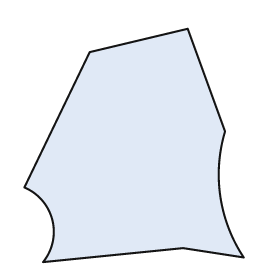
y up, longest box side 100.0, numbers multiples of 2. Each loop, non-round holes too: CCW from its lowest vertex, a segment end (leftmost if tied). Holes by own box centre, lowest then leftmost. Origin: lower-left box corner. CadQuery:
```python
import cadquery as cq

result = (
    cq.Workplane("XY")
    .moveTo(8.0, 0.0)
    .lineTo(68.0, 6.0)
    .lineTo(94.0, 2.0)
    .threePointArc((84.0, 28.0), (86.0, 56.0))
    .lineTo(70.0, 100.0)
    .lineTo(28.0, 90.0)
    .lineTo(0.0, 32.0)
    .threePointArc((12.0, 18.0), (8.0, 0.0))
    .close()
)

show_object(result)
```